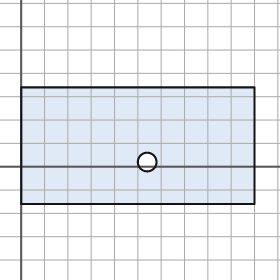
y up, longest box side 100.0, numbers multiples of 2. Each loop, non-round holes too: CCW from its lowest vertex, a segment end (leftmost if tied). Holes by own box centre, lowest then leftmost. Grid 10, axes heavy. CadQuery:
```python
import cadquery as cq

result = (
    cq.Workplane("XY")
    .moveTo(0.0, -16.0)
    .lineTo(100.0, -16.0)
    .lineTo(100.0, 34.0)
    .lineTo(0.0, 34.0)
    .close()
    .moveTo(54.0, 2.0)
    .circle(4.0)
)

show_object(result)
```